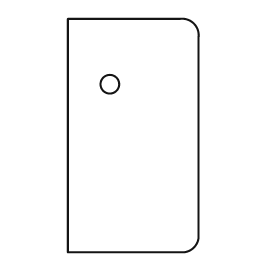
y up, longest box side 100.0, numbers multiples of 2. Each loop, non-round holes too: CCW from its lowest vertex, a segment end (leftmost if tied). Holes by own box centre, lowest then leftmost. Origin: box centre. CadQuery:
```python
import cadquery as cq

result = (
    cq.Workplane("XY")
    .moveTo(-28.0, -50.0)
    .lineTo(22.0, -50.0)
    .threePointArc((26.0, -48.0), (28.0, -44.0))
    .lineTo(28.0, 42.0)
    .threePointArc((26.0, 48.0), (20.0, 50.0))
    .lineTo(-28.0, 50.0)
    .close()
    .moveTo(-10.0, 22.0)
    .circle(4.0)
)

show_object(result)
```